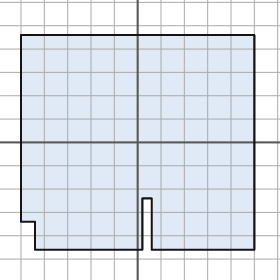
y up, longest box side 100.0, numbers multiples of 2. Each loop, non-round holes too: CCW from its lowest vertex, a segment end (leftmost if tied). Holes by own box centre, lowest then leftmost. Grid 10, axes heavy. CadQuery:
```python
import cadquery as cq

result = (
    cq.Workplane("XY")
    .moveTo(-44.0, -46.0)
    .lineTo(2.0, -46.0)
    .lineTo(2.0, -24.0)
    .lineTo(6.0, -24.0)
    .lineTo(6.0, -46.0)
    .lineTo(50.0, -46.0)
    .lineTo(50.0, 46.0)
    .lineTo(-50.0, 46.0)
    .lineTo(-50.0, -34.0)
    .lineTo(-44.0, -34.0)
    .close()
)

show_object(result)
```